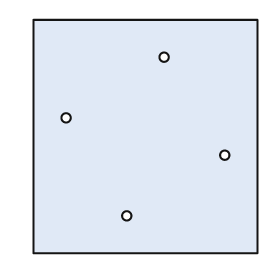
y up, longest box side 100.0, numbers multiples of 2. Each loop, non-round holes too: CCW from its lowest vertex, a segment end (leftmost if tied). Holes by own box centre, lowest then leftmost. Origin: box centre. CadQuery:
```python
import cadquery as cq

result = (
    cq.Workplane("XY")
    .moveTo(-48.0, -50.0)
    .lineTo(48.0, -50.0)
    .lineTo(48.0, 50.0)
    .lineTo(-48.0, 50.0)
    .close()
    .moveTo(-8.0, -34.0)
    .circle(2.0)
    .moveTo(34.0, -8.0)
    .circle(2.0)
    .moveTo(-34.0, 8.0)
    .circle(2.0)
    .moveTo(8.0, 34.0)
    .circle(2.0)
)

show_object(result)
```